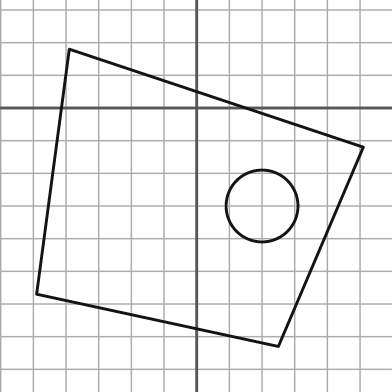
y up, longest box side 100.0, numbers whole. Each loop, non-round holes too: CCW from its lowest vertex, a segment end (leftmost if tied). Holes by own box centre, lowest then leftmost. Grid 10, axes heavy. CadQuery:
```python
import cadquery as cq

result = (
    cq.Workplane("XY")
    .moveTo(25.0, -73.0)
    .lineTo(51.0, -12.0)
    .lineTo(-39.0, 18.0)
    .lineTo(-49.0, -57.0)
    .close()
    .moveTo(20.0, -30.0)
    .circle(11.0)
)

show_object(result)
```